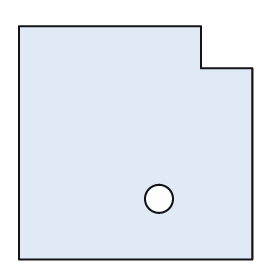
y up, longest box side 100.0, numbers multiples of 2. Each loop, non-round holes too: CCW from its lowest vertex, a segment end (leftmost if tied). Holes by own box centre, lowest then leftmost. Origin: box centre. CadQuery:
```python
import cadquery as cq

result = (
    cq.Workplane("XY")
    .moveTo(-50.0, -50.0)
    .lineTo(50.0, -50.0)
    .lineTo(50.0, 32.0)
    .lineTo(28.0, 32.0)
    .lineTo(28.0, 50.0)
    .lineTo(-50.0, 50.0)
    .close()
    .moveTo(10.0, -24.0)
    .circle(6.0)
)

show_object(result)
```